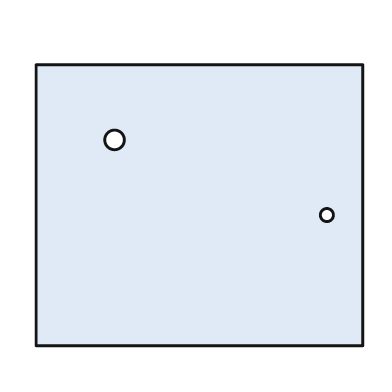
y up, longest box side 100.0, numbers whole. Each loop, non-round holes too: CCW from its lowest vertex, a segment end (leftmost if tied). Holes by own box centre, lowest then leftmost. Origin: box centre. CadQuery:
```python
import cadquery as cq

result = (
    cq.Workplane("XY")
    .moveTo(-50.0, -43.0)
    .lineTo(50.0, -43.0)
    .lineTo(50.0, 43.0)
    .lineTo(-50.0, 43.0)
    .close()
    .moveTo(39.0, -3.0)
    .circle(2.0)
    .moveTo(-26.0, 20.0)
    .circle(3.0)
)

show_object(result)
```